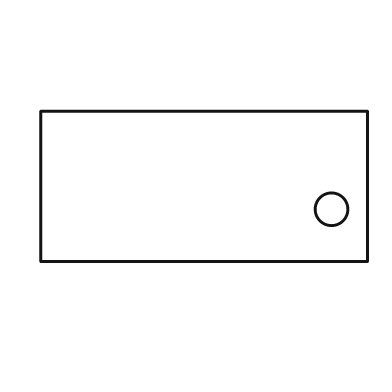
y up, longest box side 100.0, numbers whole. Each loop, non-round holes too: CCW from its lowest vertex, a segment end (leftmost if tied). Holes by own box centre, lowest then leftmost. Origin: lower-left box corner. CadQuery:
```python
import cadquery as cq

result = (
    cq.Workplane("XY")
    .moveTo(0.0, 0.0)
    .lineTo(100.0, 0.0)
    .lineTo(100.0, 46.0)
    .lineTo(0.0, 46.0)
    .close()
    .moveTo(89.0, 16.0)
    .circle(5.0)
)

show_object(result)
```